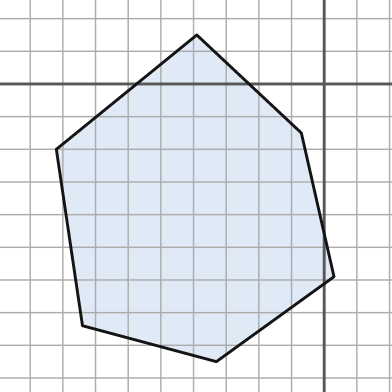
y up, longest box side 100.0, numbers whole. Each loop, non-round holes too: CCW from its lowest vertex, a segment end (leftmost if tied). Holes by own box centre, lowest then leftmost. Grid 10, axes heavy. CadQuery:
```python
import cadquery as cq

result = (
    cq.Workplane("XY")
    .moveTo(-33.0, -85.0)
    .lineTo(3.0, -59.0)
    .lineTo(-7.0, -15.0)
    .lineTo(-39.0, 15.0)
    .lineTo(-82.0, -20.0)
    .lineTo(-74.0, -74.0)
    .close()
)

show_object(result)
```